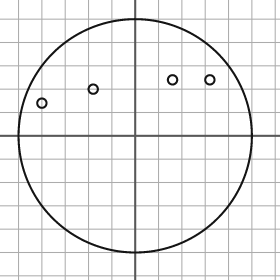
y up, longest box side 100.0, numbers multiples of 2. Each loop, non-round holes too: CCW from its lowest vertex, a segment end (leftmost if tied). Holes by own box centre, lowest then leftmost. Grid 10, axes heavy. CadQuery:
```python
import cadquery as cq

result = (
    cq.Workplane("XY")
    .moveTo(0.0, 0.0)
    .circle(50.0)
    .moveTo(-40.0, 14.0)
    .circle(2.0)
    .moveTo(-18.0, 20.0)
    .circle(2.0)
    .moveTo(16.0, 24.0)
    .circle(2.0)
    .moveTo(32.0, 24.0)
    .circle(2.0)
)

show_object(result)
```